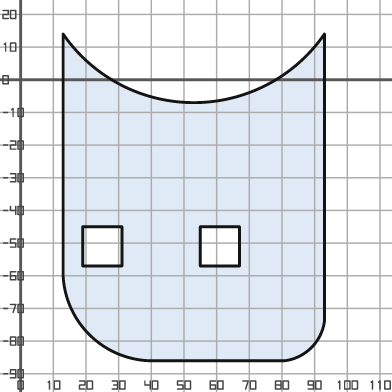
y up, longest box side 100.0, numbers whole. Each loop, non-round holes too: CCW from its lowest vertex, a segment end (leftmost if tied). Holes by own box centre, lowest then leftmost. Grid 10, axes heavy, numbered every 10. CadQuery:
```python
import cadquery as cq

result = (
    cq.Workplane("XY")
    .moveTo(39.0, -86.0)
    .lineTo(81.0, -86.0)
    .threePointArc((89.0, -82.0), (93.0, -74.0))
    .lineTo(93.0, 14.0)
    .threePointArc((53.0, -7.0), (13.0, 14.0))
    .lineTo(13.0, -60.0)
    .threePointArc((21.0, -78.0), (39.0, -86.0))
    .close()
    .moveTo(19.0, -57.0)
    .lineTo(31.0, -57.0)
    .lineTo(31.0, -45.0)
    .lineTo(19.0, -45.0)
    .close()
    .moveTo(55.0, -57.0)
    .lineTo(67.0, -57.0)
    .lineTo(67.0, -45.0)
    .lineTo(55.0, -45.0)
    .close()
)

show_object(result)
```